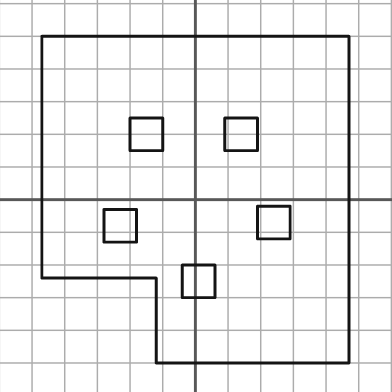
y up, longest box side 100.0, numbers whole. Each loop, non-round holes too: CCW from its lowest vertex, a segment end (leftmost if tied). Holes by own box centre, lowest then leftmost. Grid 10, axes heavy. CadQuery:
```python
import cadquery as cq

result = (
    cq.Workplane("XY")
    .moveTo(-12.0, -50.0)
    .lineTo(47.0, -50.0)
    .lineTo(47.0, 50.0)
    .lineTo(-47.0, 50.0)
    .lineTo(-47.0, -24.0)
    .lineTo(-12.0, -24.0)
    .close()
    .moveTo(-4.0, -30.0)
    .lineTo(6.0, -30.0)
    .lineTo(6.0, -20.0)
    .lineTo(-4.0, -20.0)
    .close()
    .moveTo(-28.0, -13.0)
    .lineTo(-18.0, -13.0)
    .lineTo(-18.0, -3.0)
    .lineTo(-28.0, -3.0)
    .close()
    .moveTo(19.0, -12.0)
    .lineTo(29.0, -12.0)
    .lineTo(29.0, -2.0)
    .lineTo(19.0, -2.0)
    .close()
    .moveTo(-20.0, 15.0)
    .lineTo(-10.0, 15.0)
    .lineTo(-10.0, 25.0)
    .lineTo(-20.0, 25.0)
    .close()
    .moveTo(9.0, 15.0)
    .lineTo(19.0, 15.0)
    .lineTo(19.0, 25.0)
    .lineTo(9.0, 25.0)
    .close()
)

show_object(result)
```